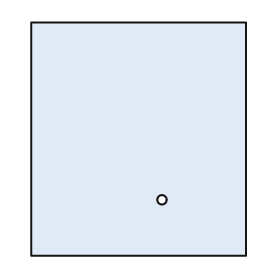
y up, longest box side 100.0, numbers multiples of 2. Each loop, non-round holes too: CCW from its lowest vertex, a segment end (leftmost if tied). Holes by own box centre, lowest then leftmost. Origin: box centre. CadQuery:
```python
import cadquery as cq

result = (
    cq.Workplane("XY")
    .moveTo(-46.0, -50.0)
    .lineTo(46.0, -50.0)
    .lineTo(46.0, 50.0)
    .lineTo(-46.0, 50.0)
    .close()
    .moveTo(10.0, -26.0)
    .circle(2.0)
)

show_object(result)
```